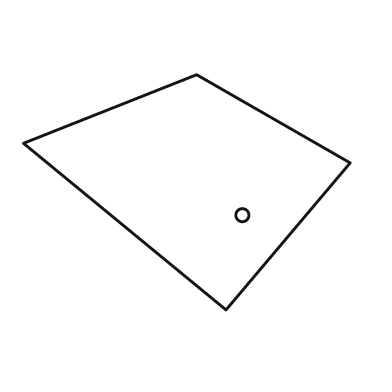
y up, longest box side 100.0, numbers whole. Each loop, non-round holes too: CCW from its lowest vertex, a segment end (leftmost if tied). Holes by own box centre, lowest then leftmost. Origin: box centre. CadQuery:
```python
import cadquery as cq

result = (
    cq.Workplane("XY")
    .moveTo(12.0, -36.0)
    .lineTo(50.0, 9.0)
    .lineTo(3.0, 36.0)
    .lineTo(-50.0, 15.0)
    .close()
    .moveTo(17.0, -7.0)
    .circle(2.0)
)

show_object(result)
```